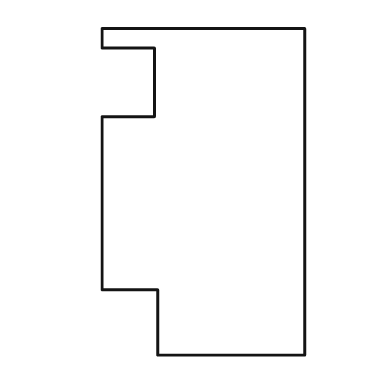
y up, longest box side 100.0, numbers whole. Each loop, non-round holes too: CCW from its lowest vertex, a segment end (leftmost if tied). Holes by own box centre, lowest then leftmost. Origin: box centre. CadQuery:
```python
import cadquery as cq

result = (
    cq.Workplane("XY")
    .moveTo(-14.0, -50.0)
    .lineTo(31.0, -50.0)
    .lineTo(31.0, 50.0)
    .lineTo(-31.0, 50.0)
    .lineTo(-31.0, 44.0)
    .lineTo(-15.0, 44.0)
    .lineTo(-15.0, 23.0)
    .lineTo(-31.0, 23.0)
    .lineTo(-31.0, -30.0)
    .lineTo(-14.0, -30.0)
    .close()
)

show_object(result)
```